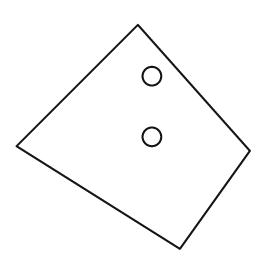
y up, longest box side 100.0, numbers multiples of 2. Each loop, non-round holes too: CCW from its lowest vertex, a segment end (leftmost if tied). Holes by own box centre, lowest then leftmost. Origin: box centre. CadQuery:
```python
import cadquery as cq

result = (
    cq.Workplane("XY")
    .moveTo(20.0, -48.0)
    .lineTo(50.0, -6.0)
    .lineTo(2.0, 48.0)
    .lineTo(-50.0, -4.0)
    .close()
    .moveTo(8.0, 0.0)
    .circle(4.0)
    .moveTo(8.0, 26.0)
    .circle(4.0)
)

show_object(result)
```